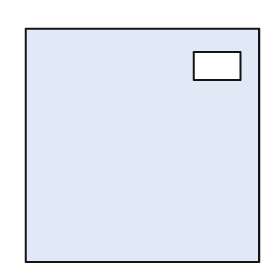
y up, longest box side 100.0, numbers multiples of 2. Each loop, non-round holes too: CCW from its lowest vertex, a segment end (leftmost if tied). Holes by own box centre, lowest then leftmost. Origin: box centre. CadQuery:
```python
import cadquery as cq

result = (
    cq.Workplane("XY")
    .moveTo(-50.0, -50.0)
    .lineTo(50.0, -50.0)
    .lineTo(50.0, 50.0)
    .lineTo(-50.0, 50.0)
    .close()
    .moveTo(22.0, 28.0)
    .lineTo(42.0, 28.0)
    .lineTo(42.0, 40.0)
    .lineTo(22.0, 40.0)
    .close()
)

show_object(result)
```